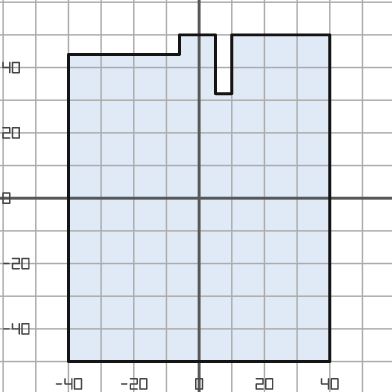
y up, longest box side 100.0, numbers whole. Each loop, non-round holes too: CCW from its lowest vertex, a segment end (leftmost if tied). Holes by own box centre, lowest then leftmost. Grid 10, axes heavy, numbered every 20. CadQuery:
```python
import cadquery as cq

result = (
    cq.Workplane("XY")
    .moveTo(-40.0, -50.0)
    .lineTo(40.0, -50.0)
    .lineTo(40.0, 50.0)
    .lineTo(10.0, 50.0)
    .lineTo(10.0, 32.0)
    .lineTo(5.0, 32.0)
    .lineTo(5.0, 50.0)
    .lineTo(-6.0, 50.0)
    .lineTo(-6.0, 44.0)
    .lineTo(-40.0, 44.0)
    .close()
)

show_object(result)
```